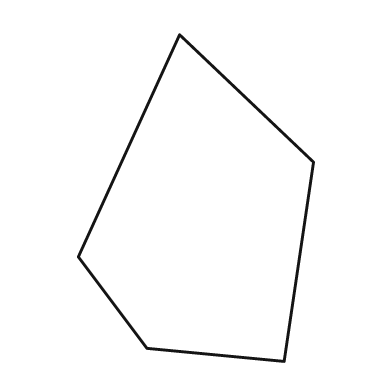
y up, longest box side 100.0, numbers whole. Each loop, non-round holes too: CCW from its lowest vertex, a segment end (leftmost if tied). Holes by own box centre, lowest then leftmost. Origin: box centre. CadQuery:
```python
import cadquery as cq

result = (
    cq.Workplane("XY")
    .moveTo(27.0, -50.0)
    .lineTo(36.0, 11.0)
    .lineTo(-5.0, 50.0)
    .lineTo(-36.0, -18.0)
    .lineTo(-15.0, -46.0)
    .close()
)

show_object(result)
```